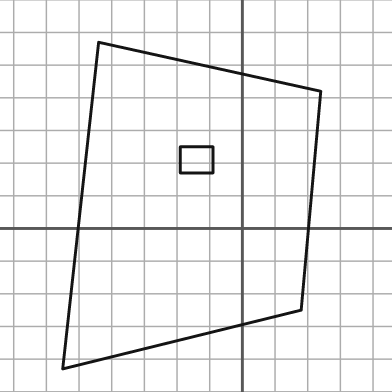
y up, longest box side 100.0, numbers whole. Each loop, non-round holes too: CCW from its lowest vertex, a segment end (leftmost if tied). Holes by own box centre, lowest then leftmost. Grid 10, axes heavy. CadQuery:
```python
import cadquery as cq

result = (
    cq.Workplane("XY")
    .moveTo(-55.0, -43.0)
    .lineTo(18.0, -25.0)
    .lineTo(24.0, 42.0)
    .lineTo(-44.0, 57.0)
    .close()
    .moveTo(-19.0, 17.0)
    .lineTo(-9.0, 17.0)
    .lineTo(-9.0, 25.0)
    .lineTo(-19.0, 25.0)
    .close()
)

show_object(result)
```